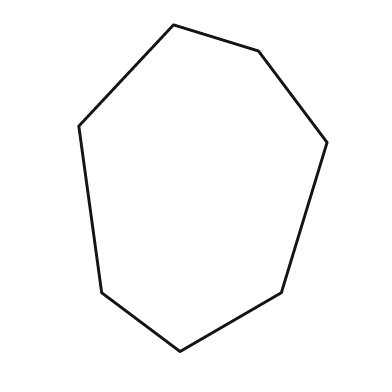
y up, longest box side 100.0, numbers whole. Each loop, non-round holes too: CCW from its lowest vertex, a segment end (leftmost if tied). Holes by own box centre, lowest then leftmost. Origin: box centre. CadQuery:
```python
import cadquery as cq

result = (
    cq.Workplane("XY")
    .moveTo(-7.0, -50.0)
    .lineTo(24.0, -32.0)
    .lineTo(38.0, 14.0)
    .lineTo(17.0, 42.0)
    .lineTo(-9.0, 50.0)
    .lineTo(-38.0, 19.0)
    .lineTo(-31.0, -32.0)
    .close()
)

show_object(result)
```